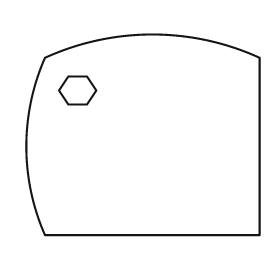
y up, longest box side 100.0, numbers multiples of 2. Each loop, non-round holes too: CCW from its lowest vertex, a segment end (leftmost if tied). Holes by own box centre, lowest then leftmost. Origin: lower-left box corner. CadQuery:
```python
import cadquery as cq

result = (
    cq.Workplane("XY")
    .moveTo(8.0, 0.0)
    .lineTo(100.0, 0.0)
    .lineTo(100.0, 76.0)
    .threePointArc((54.0, 86.0), (8.0, 76.0))
    .threePointArc((0.0, 38.0), (8.0, 0.0))
    .close()
    .moveTo(18.0, 56.0)
    .lineTo(26.0, 56.0)
    .lineTo(30.0, 62.0)
    .lineTo(26.0, 68.0)
    .lineTo(18.0, 68.0)
    .lineTo(14.0, 62.0)
    .close()
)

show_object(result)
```